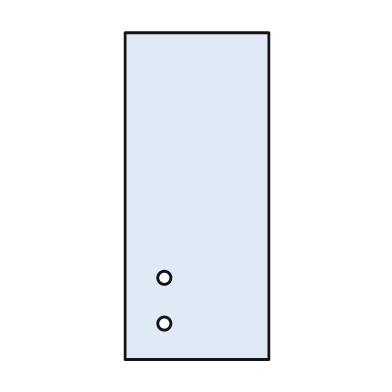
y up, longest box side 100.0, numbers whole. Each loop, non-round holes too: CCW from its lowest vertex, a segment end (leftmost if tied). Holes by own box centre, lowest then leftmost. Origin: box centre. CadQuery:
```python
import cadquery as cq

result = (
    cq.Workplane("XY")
    .moveTo(-22.0, -50.0)
    .lineTo(22.0, -50.0)
    .lineTo(22.0, 50.0)
    .lineTo(-22.0, 50.0)
    .close()
    .moveTo(-10.0, -39.0)
    .circle(2.0)
    .moveTo(-10.0, -25.0)
    .circle(2.0)
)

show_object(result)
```